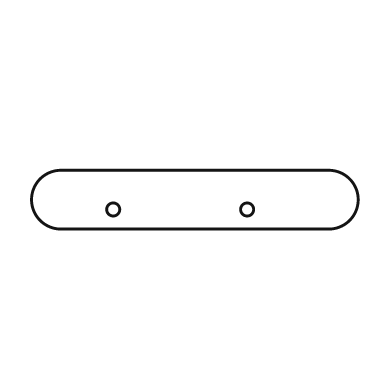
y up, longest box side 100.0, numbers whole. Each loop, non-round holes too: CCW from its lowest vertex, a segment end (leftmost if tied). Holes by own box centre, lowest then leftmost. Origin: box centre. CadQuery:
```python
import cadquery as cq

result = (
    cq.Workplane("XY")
    .moveTo(-41.0, -9.0)
    .lineTo(41.0, -9.0)
    .threePointArc((50.0, 0.0), (41.0, 9.0))
    .lineTo(-41.0, 9.0)
    .threePointArc((-50.0, 0.0), (-41.0, -9.0))
    .close()
    .moveTo(-25.0, -3.0)
    .circle(2.0)
    .moveTo(16.0, -3.0)
    .circle(2.0)
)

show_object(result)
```